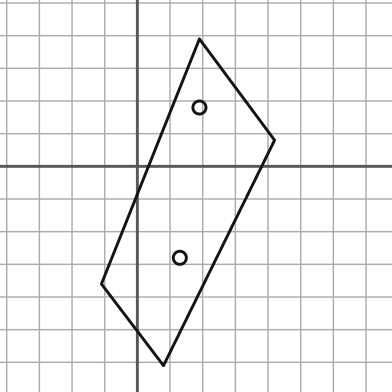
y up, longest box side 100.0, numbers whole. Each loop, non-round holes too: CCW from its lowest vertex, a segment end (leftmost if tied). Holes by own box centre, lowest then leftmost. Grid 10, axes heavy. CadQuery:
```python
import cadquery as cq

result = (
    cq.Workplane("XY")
    .moveTo(8.0, -61.0)
    .lineTo(42.0, 8.0)
    .lineTo(19.0, 39.0)
    .lineTo(-11.0, -36.0)
    .close()
    .moveTo(13.0, -28.0)
    .circle(2.0)
    .moveTo(19.0, 18.0)
    .circle(2.0)
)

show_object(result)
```